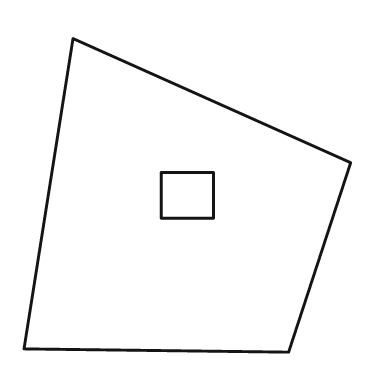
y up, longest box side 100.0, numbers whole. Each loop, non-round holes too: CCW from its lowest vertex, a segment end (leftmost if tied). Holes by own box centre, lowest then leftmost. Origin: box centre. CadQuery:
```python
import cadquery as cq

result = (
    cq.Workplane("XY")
    .moveTo(31.0, -48.0)
    .lineTo(50.0, 10.0)
    .lineTo(-35.0, 48.0)
    .lineTo(-50.0, -47.0)
    .close()
    .moveTo(-8.0, -7.0)
    .lineTo(8.0, -7.0)
    .lineTo(8.0, 7.0)
    .lineTo(-8.0, 7.0)
    .close()
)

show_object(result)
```